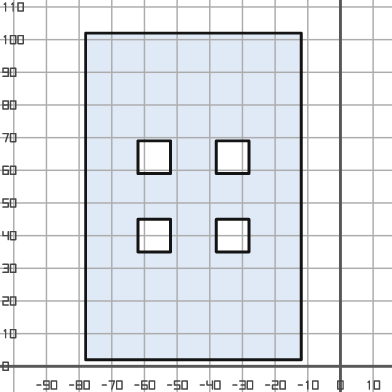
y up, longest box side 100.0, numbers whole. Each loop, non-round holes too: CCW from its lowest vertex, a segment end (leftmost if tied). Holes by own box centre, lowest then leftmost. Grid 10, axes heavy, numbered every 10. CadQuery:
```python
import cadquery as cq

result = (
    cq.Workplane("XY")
    .moveTo(-78.0, 2.0)
    .lineTo(-12.0, 2.0)
    .lineTo(-12.0, 102.0)
    .lineTo(-78.0, 102.0)
    .close()
    .moveTo(-62.0, 35.0)
    .lineTo(-52.0, 35.0)
    .lineTo(-52.0, 45.0)
    .lineTo(-62.0, 45.0)
    .close()
    .moveTo(-38.0, 35.0)
    .lineTo(-28.0, 35.0)
    .lineTo(-28.0, 45.0)
    .lineTo(-38.0, 45.0)
    .close()
    .moveTo(-62.0, 59.0)
    .lineTo(-52.0, 59.0)
    .lineTo(-52.0, 69.0)
    .lineTo(-62.0, 69.0)
    .close()
    .moveTo(-38.0, 59.0)
    .lineTo(-28.0, 59.0)
    .lineTo(-28.0, 69.0)
    .lineTo(-38.0, 69.0)
    .close()
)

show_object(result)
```